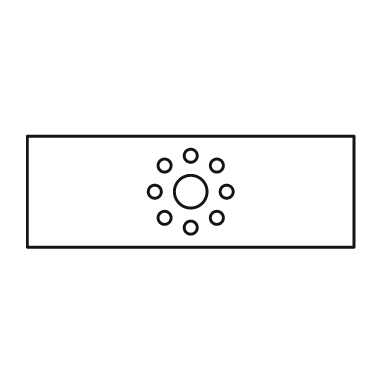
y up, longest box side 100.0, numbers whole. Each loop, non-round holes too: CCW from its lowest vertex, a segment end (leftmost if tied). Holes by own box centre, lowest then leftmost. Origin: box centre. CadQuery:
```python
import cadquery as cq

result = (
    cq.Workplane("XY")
    .moveTo(-50.0, -17.0)
    .lineTo(50.0, -17.0)
    .lineTo(50.0, 17.0)
    .lineTo(-50.0, 17.0)
    .close()
    .moveTo(0.0, -11.0)
    .circle(2.0)
    .moveTo(-8.0, -8.0)
    .circle(2.0)
    .moveTo(8.0, -8.0)
    .circle(2.0)
    .moveTo(-11.0, 0.0)
    .circle(2.0)
    .moveTo(0.0, 0.0)
    .circle(5.0)
    .moveTo(11.0, 0.0)
    .circle(2.0)
    .moveTo(-8.0, 8.0)
    .circle(2.0)
    .moveTo(8.0, 8.0)
    .circle(2.0)
    .moveTo(0.0, 11.0)
    .circle(2.0)
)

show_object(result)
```